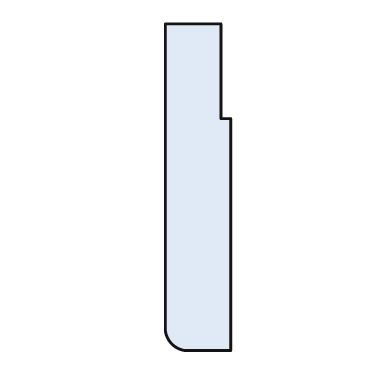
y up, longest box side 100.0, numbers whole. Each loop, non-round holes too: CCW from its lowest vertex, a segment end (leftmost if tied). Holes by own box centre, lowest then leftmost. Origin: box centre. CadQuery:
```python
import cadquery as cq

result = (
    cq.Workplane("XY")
    .moveTo(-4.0, -50.0)
    .lineTo(10.0, -50.0)
    .lineTo(10.0, 21.0)
    .lineTo(7.0, 21.0)
    .lineTo(7.0, 50.0)
    .lineTo(-10.0, 50.0)
    .lineTo(-10.0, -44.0)
    .threePointArc((-8.0, -48.0), (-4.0, -50.0))
    .close()
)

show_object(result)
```